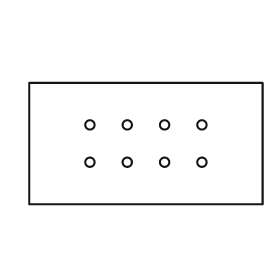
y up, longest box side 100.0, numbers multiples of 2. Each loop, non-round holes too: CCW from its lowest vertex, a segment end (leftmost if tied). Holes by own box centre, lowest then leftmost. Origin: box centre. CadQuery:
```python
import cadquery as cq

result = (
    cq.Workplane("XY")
    .moveTo(-50.0, -26.0)
    .lineTo(50.0, -26.0)
    .lineTo(50.0, 26.0)
    .lineTo(-50.0, 26.0)
    .close()
    .moveTo(-24.0, -8.0)
    .circle(2.0)
    .moveTo(-8.0, -8.0)
    .circle(2.0)
    .moveTo(8.0, -8.0)
    .circle(2.0)
    .moveTo(24.0, -8.0)
    .circle(2.0)
    .moveTo(-24.0, 8.0)
    .circle(2.0)
    .moveTo(-8.0, 8.0)
    .circle(2.0)
    .moveTo(8.0, 8.0)
    .circle(2.0)
    .moveTo(24.0, 8.0)
    .circle(2.0)
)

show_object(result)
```